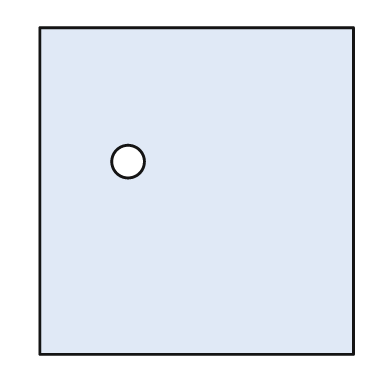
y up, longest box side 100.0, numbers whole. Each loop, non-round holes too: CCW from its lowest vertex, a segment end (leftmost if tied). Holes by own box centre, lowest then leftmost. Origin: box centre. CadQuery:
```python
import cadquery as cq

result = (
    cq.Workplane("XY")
    .moveTo(-48.0, -50.0)
    .lineTo(48.0, -50.0)
    .lineTo(48.0, 50.0)
    .lineTo(-48.0, 50.0)
    .close()
    .moveTo(-21.0, 9.0)
    .circle(5.0)
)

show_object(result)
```